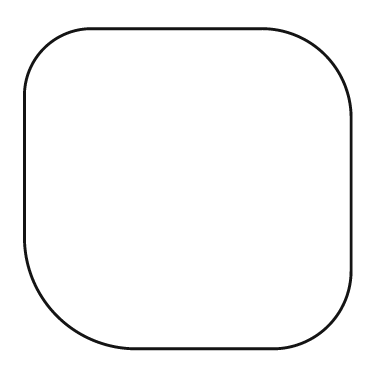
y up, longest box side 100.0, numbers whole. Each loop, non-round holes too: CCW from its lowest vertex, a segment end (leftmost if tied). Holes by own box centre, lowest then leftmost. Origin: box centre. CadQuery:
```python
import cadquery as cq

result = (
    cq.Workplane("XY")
    .moveTo(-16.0, -49.0)
    .lineTo(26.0, -49.0)
    .threePointArc((43.0, -42.0), (50.0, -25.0))
    .lineTo(50.0, 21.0)
    .threePointArc((42.0, 41.0), (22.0, 49.0))
    .lineTo(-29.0, 49.0)
    .threePointArc((-44.0, 43.0), (-50.0, 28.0))
    .lineTo(-50.0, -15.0)
    .threePointArc((-40.0, -39.0), (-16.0, -49.0))
    .close()
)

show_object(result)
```